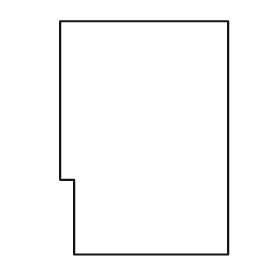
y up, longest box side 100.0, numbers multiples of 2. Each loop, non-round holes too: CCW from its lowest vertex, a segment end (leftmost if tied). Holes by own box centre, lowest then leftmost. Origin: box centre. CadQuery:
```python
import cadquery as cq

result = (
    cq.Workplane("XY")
    .moveTo(-30.0, -50.0)
    .lineTo(36.0, -50.0)
    .lineTo(36.0, 50.0)
    .lineTo(-36.0, 50.0)
    .lineTo(-36.0, -18.0)
    .lineTo(-30.0, -18.0)
    .close()
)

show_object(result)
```